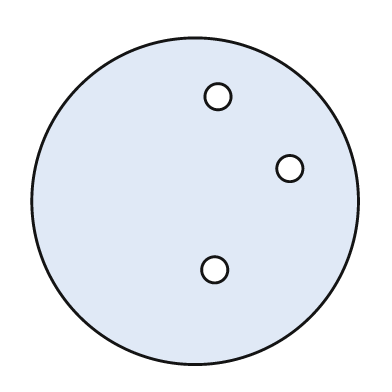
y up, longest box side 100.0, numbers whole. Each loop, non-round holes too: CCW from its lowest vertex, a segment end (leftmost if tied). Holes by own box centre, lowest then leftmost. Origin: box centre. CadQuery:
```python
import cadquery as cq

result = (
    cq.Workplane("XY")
    .moveTo(0.0, 0.0)
    .circle(50.0)
    .moveTo(6.0, -21.0)
    .circle(4.0)
    .moveTo(29.0, 10.0)
    .circle(4.0)
    .moveTo(7.0, 32.0)
    .circle(4.0)
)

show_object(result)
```